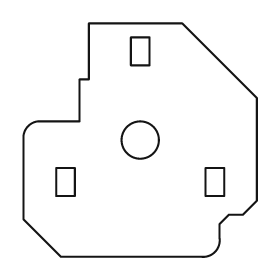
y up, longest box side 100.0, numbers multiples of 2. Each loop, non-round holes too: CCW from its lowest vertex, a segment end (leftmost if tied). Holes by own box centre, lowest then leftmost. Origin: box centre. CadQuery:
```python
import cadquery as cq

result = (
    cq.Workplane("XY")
    .moveTo(-34.0, -50.0)
    .lineTo(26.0, -50.0)
    .threePointArc((32.0, -48.0), (34.0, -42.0))
    .lineTo(34.0, -36.0)
    .lineTo(38.0, -32.0)
    .lineTo(44.0, -32.0)
    .lineTo(50.0, -26.0)
    .lineTo(50.0, 18.0)
    .lineTo(18.0, 50.0)
    .lineTo(-22.0, 50.0)
    .lineTo(-22.0, 26.0)
    .lineTo(-26.0, 26.0)
    .lineTo(-26.0, 8.0)
    .lineTo(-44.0, 8.0)
    .threePointArc((-48.0, 6.0), (-50.0, 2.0))
    .lineTo(-50.0, -34.0)
    .close()
    .moveTo(-36.0, -24.0)
    .lineTo(-28.0, -24.0)
    .lineTo(-28.0, -12.0)
    .lineTo(-36.0, -12.0)
    .close()
    .moveTo(28.0, -24.0)
    .lineTo(36.0, -24.0)
    .lineTo(36.0, -12.0)
    .lineTo(28.0, -12.0)
    .close()
    .moveTo(0.0, 0.0)
    .circle(8.0)
    .moveTo(-4.0, 32.0)
    .lineTo(4.0, 32.0)
    .lineTo(4.0, 44.0)
    .lineTo(-4.0, 44.0)
    .close()
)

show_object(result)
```